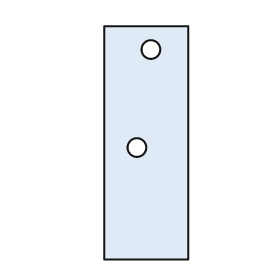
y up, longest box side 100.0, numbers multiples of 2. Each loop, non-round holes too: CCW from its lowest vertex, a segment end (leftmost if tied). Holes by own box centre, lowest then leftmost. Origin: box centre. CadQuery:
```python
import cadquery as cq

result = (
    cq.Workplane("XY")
    .moveTo(-18.0, -50.0)
    .lineTo(18.0, -50.0)
    .lineTo(18.0, 50.0)
    .lineTo(-18.0, 50.0)
    .close()
    .moveTo(-4.0, -2.0)
    .circle(4.0)
    .moveTo(2.0, 40.0)
    .circle(4.0)
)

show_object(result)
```